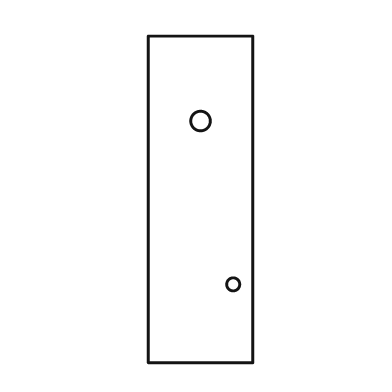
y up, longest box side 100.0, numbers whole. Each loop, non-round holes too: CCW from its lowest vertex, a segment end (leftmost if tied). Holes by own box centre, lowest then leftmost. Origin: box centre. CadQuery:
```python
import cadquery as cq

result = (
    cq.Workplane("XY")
    .moveTo(-16.0, -50.0)
    .lineTo(16.0, -50.0)
    .lineTo(16.0, 50.0)
    .lineTo(-16.0, 50.0)
    .close()
    .moveTo(10.0, -26.0)
    .circle(2.0)
    .moveTo(0.0, 24.0)
    .circle(3.0)
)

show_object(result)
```